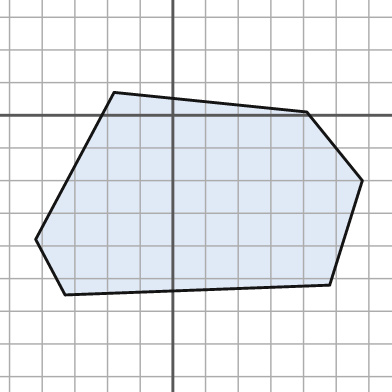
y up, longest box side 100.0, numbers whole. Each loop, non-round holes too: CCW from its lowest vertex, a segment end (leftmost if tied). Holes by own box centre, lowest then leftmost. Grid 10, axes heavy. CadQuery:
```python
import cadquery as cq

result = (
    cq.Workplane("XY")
    .moveTo(-33.0, -55.0)
    .lineTo(48.0, -52.0)
    .lineTo(58.0, -20.0)
    .lineTo(41.0, 1.0)
    .lineTo(-18.0, 7.0)
    .lineTo(-42.0, -38.0)
    .close()
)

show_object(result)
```